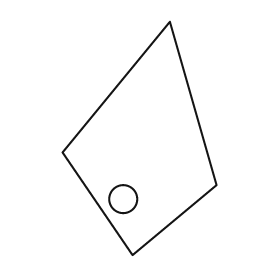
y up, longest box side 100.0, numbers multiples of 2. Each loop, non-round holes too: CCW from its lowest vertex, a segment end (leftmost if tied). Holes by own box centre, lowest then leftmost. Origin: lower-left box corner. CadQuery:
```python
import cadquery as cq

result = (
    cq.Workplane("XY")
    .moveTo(30.0, 0.0)
    .lineTo(66.0, 30.0)
    .lineTo(46.0, 100.0)
    .lineTo(0.0, 44.0)
    .close()
    .moveTo(26.0, 24.0)
    .circle(6.0)
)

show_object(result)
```